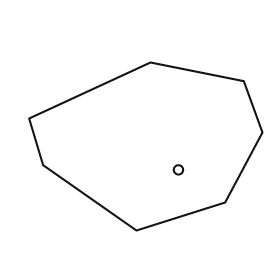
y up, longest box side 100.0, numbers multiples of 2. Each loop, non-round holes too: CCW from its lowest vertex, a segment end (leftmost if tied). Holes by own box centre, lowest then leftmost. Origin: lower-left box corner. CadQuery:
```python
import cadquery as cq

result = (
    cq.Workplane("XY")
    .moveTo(46.0, 0.0)
    .lineTo(84.0, 12.0)
    .lineTo(100.0, 42.0)
    .lineTo(92.0, 64.0)
    .lineTo(52.0, 72.0)
    .lineTo(0.0, 48.0)
    .lineTo(6.0, 28.0)
    .close()
    .moveTo(64.0, 26.0)
    .circle(2.0)
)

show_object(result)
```